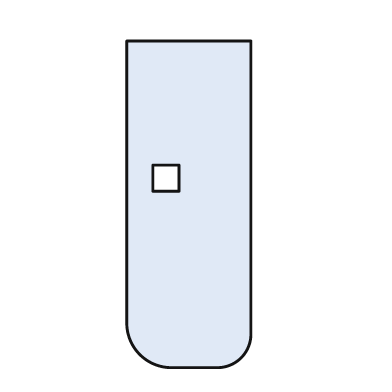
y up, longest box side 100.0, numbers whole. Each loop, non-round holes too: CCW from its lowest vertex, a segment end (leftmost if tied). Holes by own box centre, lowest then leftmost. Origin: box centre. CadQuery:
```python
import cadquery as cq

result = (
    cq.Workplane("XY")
    .moveTo(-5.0, -50.0)
    .lineTo(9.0, -50.0)
    .threePointArc((16.0, -47.0), (19.0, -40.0))
    .lineTo(19.0, 50.0)
    .lineTo(-19.0, 50.0)
    .lineTo(-19.0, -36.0)
    .threePointArc((-15.0, -46.0), (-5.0, -50.0))
    .close()
    .moveTo(-11.0, 4.0)
    .lineTo(-3.0, 4.0)
    .lineTo(-3.0, 12.0)
    .lineTo(-11.0, 12.0)
    .close()
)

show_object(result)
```